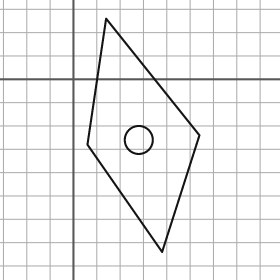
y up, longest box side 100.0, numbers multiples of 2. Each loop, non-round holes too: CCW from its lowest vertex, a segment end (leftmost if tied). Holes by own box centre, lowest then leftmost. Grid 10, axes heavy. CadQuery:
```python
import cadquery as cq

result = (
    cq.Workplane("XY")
    .moveTo(38.0, -74.0)
    .lineTo(54.0, -24.0)
    .lineTo(14.0, 26.0)
    .lineTo(6.0, -28.0)
    .close()
    .moveTo(28.0, -26.0)
    .circle(6.0)
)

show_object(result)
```